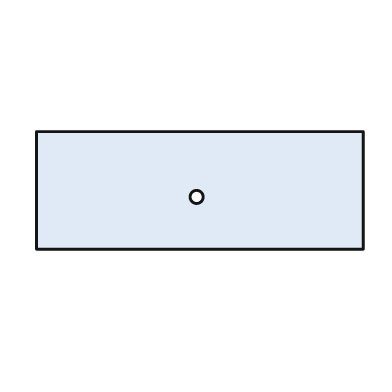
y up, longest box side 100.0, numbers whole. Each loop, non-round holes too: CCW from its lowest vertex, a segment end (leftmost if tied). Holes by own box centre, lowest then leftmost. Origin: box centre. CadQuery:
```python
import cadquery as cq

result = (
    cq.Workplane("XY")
    .moveTo(-50.0, -18.0)
    .lineTo(50.0, -18.0)
    .lineTo(50.0, 18.0)
    .lineTo(-50.0, 18.0)
    .close()
    .moveTo(-1.0, -2.0)
    .circle(2.0)
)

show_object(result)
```